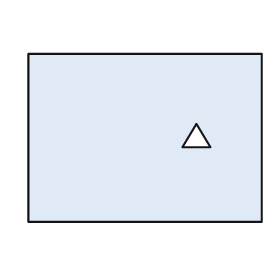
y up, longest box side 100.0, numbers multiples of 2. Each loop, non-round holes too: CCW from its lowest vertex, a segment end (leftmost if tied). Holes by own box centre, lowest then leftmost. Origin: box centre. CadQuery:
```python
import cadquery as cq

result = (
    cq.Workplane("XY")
    .moveTo(-50.0, -36.0)
    .lineTo(50.0, -36.0)
    .lineTo(50.0, 36.0)
    .lineTo(-50.0, 36.0)
    .close()
    .moveTo(16.0, -4.0)
    .lineTo(28.0, -4.0)
    .lineTo(22.0, 6.0)
    .close()
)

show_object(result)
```